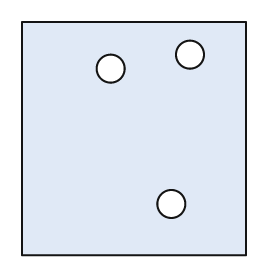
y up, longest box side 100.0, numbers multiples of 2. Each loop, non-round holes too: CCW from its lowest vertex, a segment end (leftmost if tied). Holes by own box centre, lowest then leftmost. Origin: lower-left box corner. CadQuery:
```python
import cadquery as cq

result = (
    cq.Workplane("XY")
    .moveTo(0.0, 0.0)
    .lineTo(96.0, 0.0)
    .lineTo(96.0, 100.0)
    .lineTo(0.0, 100.0)
    .close()
    .moveTo(64.0, 22.0)
    .circle(6.0)
    .moveTo(38.0, 80.0)
    .circle(6.0)
    .moveTo(72.0, 86.0)
    .circle(6.0)
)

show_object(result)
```